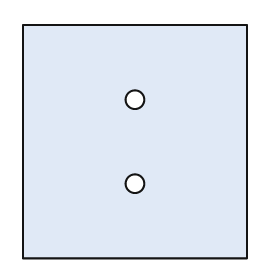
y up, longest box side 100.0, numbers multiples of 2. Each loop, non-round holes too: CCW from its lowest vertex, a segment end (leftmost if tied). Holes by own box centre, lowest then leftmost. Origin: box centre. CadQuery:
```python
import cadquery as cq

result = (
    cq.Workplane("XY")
    .moveTo(-48.0, -50.0)
    .lineTo(48.0, -50.0)
    .lineTo(48.0, 50.0)
    .lineTo(-48.0, 50.0)
    .close()
    .moveTo(0.0, -18.0)
    .circle(4.0)
    .moveTo(0.0, 18.0)
    .circle(4.0)
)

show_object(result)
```